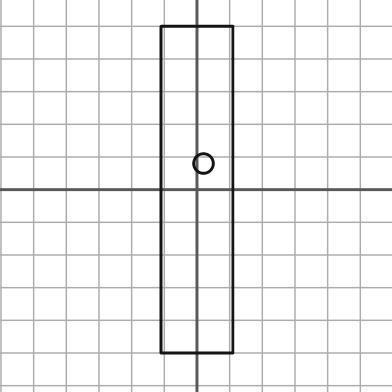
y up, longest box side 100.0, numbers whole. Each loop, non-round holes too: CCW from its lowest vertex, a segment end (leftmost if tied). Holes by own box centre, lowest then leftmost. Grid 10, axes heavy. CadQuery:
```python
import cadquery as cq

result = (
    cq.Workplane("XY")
    .moveTo(-11.0, -50.0)
    .lineTo(11.0, -50.0)
    .lineTo(11.0, 50.0)
    .lineTo(-11.0, 50.0)
    .close()
    .moveTo(2.0, 8.0)
    .circle(3.0)
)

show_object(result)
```